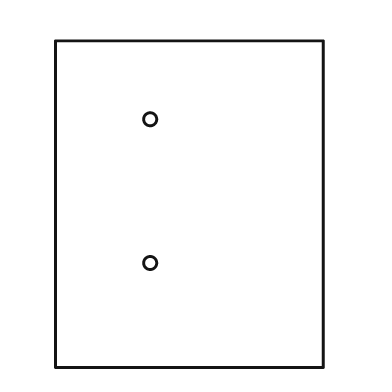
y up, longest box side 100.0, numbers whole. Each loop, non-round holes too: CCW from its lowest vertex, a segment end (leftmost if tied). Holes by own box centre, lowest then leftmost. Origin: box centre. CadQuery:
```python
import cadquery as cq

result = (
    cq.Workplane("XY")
    .moveTo(-41.0, -50.0)
    .lineTo(41.0, -50.0)
    .lineTo(41.0, 50.0)
    .lineTo(-41.0, 50.0)
    .close()
    .moveTo(-12.0, -18.0)
    .circle(2.0)
    .moveTo(-12.0, 26.0)
    .circle(2.0)
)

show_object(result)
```